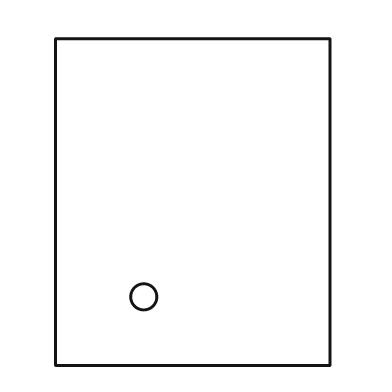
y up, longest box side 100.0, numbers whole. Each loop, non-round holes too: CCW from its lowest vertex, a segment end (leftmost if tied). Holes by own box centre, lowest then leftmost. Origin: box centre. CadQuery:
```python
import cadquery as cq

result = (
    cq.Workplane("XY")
    .moveTo(-42.0, -50.0)
    .lineTo(42.0, -50.0)
    .lineTo(42.0, 50.0)
    .lineTo(-42.0, 50.0)
    .close()
    .moveTo(-15.0, -29.0)
    .circle(4.0)
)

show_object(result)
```